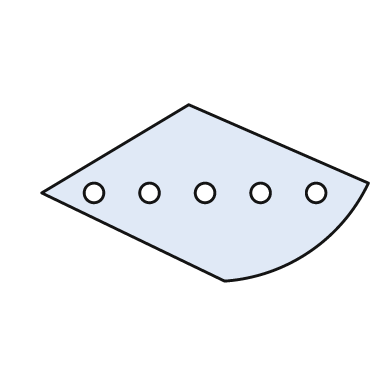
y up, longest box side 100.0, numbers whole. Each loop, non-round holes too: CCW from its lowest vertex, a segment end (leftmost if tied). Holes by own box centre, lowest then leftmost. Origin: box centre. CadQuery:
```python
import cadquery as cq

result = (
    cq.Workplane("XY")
    .moveTo(6.0, -27.0)
    .threePointArc((32.0, -18.0), (50.0, 3.0))
    .lineTo(-5.0, 27.0)
    .lineTo(-50.0, 0.0)
    .close()
    .moveTo(-34.0, 0.0)
    .circle(3.0)
    .moveTo(-17.0, 0.0)
    .circle(3.0)
    .moveTo(0.0, 0.0)
    .circle(3.0)
    .moveTo(17.0, 0.0)
    .circle(3.0)
    .moveTo(34.0, 0.0)
    .circle(3.0)
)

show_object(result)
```